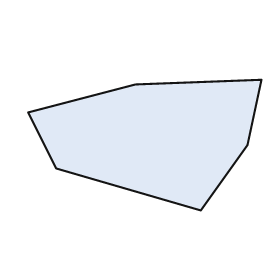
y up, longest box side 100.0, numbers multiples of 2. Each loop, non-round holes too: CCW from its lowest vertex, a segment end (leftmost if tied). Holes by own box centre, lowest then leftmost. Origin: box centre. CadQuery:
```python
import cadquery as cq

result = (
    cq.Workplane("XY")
    .moveTo(24.0, -28.0)
    .lineTo(44.0, 0.0)
    .lineTo(50.0, 28.0)
    .lineTo(-4.0, 26.0)
    .lineTo(-50.0, 14.0)
    .lineTo(-38.0, -10.0)
    .close()
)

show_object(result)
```